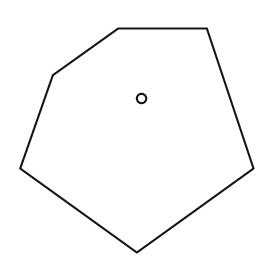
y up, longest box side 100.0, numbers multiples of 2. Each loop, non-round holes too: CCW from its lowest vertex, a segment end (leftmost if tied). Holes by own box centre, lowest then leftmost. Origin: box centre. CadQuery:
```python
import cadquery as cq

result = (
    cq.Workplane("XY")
    .moveTo(0.0, -48.0)
    .lineTo(50.0, -12.0)
    .lineTo(30.0, 48.0)
    .lineTo(-8.0, 48.0)
    .lineTo(-36.0, 28.0)
    .lineTo(-50.0, -12.0)
    .close()
    .moveTo(2.0, 18.0)
    .circle(2.0)
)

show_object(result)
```